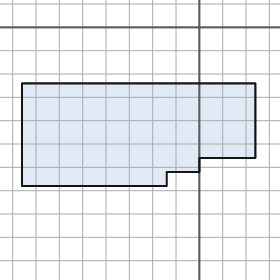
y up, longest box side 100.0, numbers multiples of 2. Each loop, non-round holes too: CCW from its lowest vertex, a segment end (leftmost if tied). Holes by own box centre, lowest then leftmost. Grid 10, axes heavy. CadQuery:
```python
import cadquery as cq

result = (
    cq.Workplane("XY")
    .moveTo(-76.0, -68.0)
    .lineTo(-14.0, -68.0)
    .lineTo(-14.0, -62.0)
    .lineTo(0.0, -62.0)
    .lineTo(0.0, -56.0)
    .lineTo(24.0, -56.0)
    .lineTo(24.0, -24.0)
    .lineTo(-76.0, -24.0)
    .close()
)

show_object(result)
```